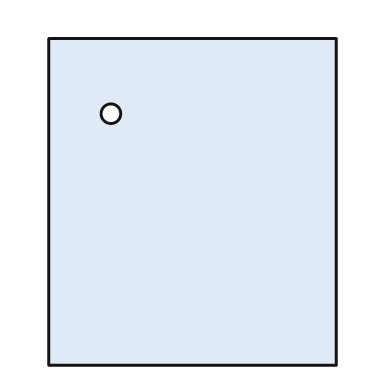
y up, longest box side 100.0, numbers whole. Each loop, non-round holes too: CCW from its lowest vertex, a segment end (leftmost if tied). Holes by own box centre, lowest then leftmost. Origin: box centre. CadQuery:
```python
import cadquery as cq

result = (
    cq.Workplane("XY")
    .moveTo(-44.0, -50.0)
    .lineTo(44.0, -50.0)
    .lineTo(44.0, 50.0)
    .lineTo(-44.0, 50.0)
    .close()
    .moveTo(-25.0, 27.0)
    .circle(3.0)
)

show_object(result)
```